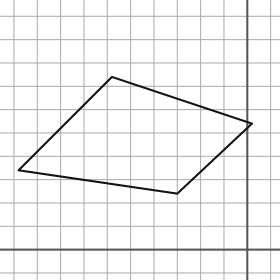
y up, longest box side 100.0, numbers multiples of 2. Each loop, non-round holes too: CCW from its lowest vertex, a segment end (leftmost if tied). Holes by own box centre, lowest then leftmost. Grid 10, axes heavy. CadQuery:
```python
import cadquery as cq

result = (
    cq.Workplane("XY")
    .moveTo(-30.0, 24.0)
    .lineTo(2.0, 54.0)
    .lineTo(-58.0, 74.0)
    .lineTo(-98.0, 34.0)
    .close()
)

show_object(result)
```